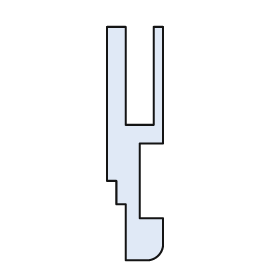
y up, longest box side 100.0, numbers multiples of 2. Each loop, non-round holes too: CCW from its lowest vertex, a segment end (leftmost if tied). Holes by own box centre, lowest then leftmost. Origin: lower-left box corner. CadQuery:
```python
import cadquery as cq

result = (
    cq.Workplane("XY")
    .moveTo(8.0, 0.0)
    .lineTo(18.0, 0.0)
    .threePointArc((22.0, 2.0), (24.0, 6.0))
    .lineTo(24.0, 18.0)
    .lineTo(14.0, 18.0)
    .lineTo(14.0, 50.0)
    .lineTo(24.0, 50.0)
    .lineTo(24.0, 100.0)
    .lineTo(20.0, 100.0)
    .lineTo(20.0, 58.0)
    .lineTo(8.0, 58.0)
    .lineTo(8.0, 100.0)
    .lineTo(0.0, 100.0)
    .lineTo(0.0, 34.0)
    .lineTo(4.0, 34.0)
    .lineTo(4.0, 24.0)
    .lineTo(8.0, 24.0)
    .close()
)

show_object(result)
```